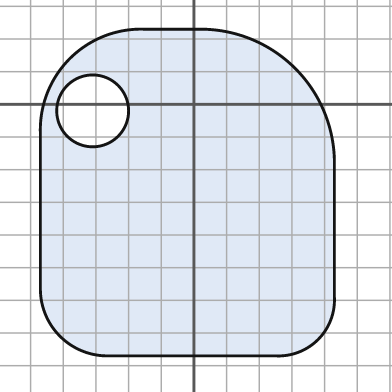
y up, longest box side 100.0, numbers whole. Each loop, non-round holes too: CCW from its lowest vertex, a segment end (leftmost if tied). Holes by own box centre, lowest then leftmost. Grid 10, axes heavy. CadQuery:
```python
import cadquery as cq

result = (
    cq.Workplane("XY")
    .moveTo(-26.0, -77.0)
    .lineTo(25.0, -77.0)
    .threePointArc((38.0, -72.0), (43.0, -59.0))
    .lineTo(43.0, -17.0)
    .threePointArc((31.0, 11.0), (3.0, 23.0))
    .lineTo(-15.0, 23.0)
    .threePointArc((-38.0, 14.0), (-47.0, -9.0))
    .lineTo(-47.0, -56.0)
    .threePointArc((-41.0, -71.0), (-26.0, -77.0))
    .close()
    .moveTo(-31.0, -2.0)
    .circle(11.0)
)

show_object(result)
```